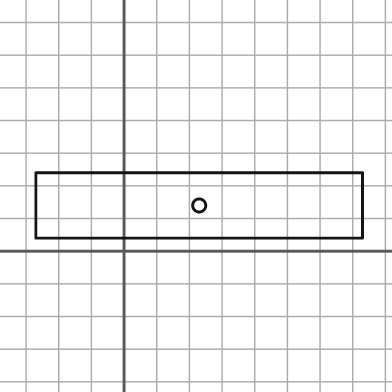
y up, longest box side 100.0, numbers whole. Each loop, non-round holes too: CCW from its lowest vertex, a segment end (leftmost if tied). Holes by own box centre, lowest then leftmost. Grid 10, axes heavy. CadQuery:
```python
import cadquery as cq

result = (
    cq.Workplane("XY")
    .moveTo(-27.0, 4.0)
    .lineTo(73.0, 4.0)
    .lineTo(73.0, 24.0)
    .lineTo(-27.0, 24.0)
    .close()
    .moveTo(23.0, 14.0)
    .circle(2.0)
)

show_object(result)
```